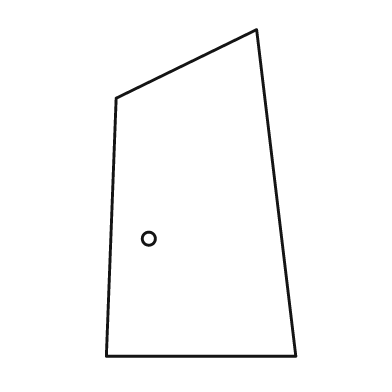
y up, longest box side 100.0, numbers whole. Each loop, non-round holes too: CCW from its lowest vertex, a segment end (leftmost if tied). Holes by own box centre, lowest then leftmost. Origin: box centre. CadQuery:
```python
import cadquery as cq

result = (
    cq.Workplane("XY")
    .moveTo(-29.0, -50.0)
    .lineTo(29.0, -50.0)
    .lineTo(17.0, 50.0)
    .lineTo(-26.0, 29.0)
    .close()
    .moveTo(-16.0, -14.0)
    .circle(2.0)
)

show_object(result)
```